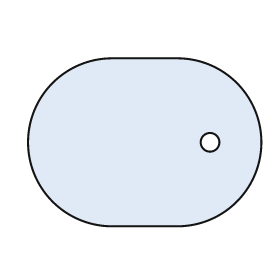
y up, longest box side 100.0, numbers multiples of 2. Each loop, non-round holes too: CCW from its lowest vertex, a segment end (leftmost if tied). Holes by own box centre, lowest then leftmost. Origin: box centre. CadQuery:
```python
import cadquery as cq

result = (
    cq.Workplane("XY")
    .moveTo(-14.0, -36.0)
    .lineTo(14.0, -36.0)
    .threePointArc((50.0, 0.0), (14.0, 36.0))
    .lineTo(-14.0, 36.0)
    .threePointArc((-50.0, 0.0), (-14.0, -36.0))
    .close()
    .moveTo(28.0, 0.0)
    .circle(4.0)
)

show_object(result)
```